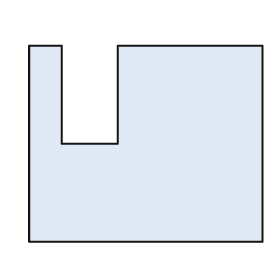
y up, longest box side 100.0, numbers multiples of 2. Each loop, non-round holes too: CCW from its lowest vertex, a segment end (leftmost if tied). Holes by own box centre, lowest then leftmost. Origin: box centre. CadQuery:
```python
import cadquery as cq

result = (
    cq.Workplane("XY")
    .moveTo(-50.0, -42.0)
    .lineTo(50.0, -42.0)
    .lineTo(50.0, 42.0)
    .lineTo(-12.0, 42.0)
    .lineTo(-12.0, 0.0)
    .lineTo(-36.0, 0.0)
    .lineTo(-36.0, 42.0)
    .lineTo(-50.0, 42.0)
    .close()
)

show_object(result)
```